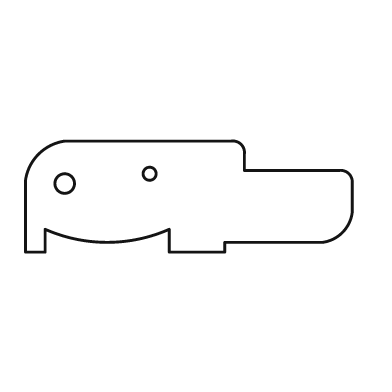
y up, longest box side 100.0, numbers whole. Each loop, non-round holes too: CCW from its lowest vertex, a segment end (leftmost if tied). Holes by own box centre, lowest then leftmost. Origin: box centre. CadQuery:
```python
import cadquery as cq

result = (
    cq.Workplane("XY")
    .moveTo(-50.0, -17.0)
    .lineTo(-44.0, -17.0)
    .lineTo(-44.0, -10.0)
    .threePointArc((-25.0, -14.0), (-6.0, -10.0))
    .lineTo(-6.0, -17.0)
    .lineTo(11.0, -17.0)
    .lineTo(11.0, -14.0)
    .lineTo(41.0, -14.0)
    .threePointArc((47.0, -11.0), (50.0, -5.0))
    .lineTo(50.0, 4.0)
    .threePointArc((49.0, 7.0), (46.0, 8.0))
    .lineTo(17.0, 8.0)
    .lineTo(17.0, 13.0)
    .threePointArc((16.0, 16.0), (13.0, 17.0))
    .lineTo(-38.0, 17.0)
    .threePointArc((-46.0, 13.0), (-50.0, 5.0))
    .close()
    .moveTo(-38.0, 4.0)
    .circle(3.0)
    .moveTo(-12.0, 7.0)
    .circle(2.0)
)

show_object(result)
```